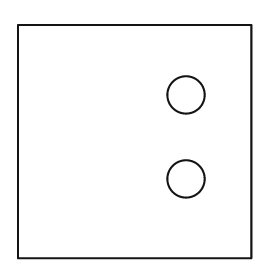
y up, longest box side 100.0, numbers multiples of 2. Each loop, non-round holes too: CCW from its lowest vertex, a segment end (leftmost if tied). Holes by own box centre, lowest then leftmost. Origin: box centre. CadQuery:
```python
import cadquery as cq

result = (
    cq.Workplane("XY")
    .moveTo(-50.0, -50.0)
    .lineTo(50.0, -50.0)
    .lineTo(50.0, 50.0)
    .lineTo(-50.0, 50.0)
    .close()
    .moveTo(22.0, -16.0)
    .circle(8.0)
    .moveTo(22.0, 20.0)
    .circle(8.0)
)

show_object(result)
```